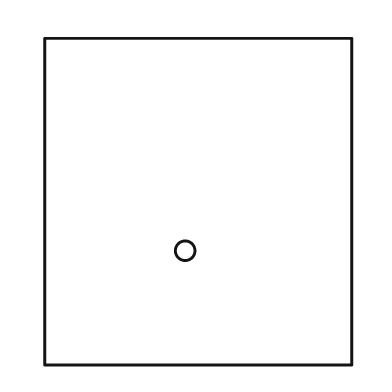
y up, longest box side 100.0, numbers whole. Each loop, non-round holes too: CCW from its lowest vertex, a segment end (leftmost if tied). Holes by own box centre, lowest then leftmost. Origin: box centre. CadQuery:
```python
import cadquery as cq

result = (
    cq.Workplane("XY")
    .moveTo(-47.0, -50.0)
    .lineTo(47.0, -50.0)
    .lineTo(47.0, 50.0)
    .lineTo(-47.0, 50.0)
    .close()
    .moveTo(-4.0, -15.0)
    .circle(3.0)
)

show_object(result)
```